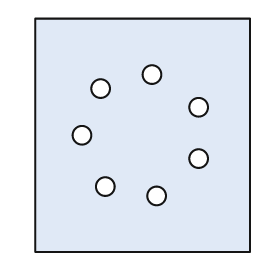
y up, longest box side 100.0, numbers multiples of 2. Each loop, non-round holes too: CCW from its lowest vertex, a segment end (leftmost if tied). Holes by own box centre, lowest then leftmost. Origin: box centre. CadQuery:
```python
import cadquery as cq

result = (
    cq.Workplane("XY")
    .moveTo(-46.0, -50.0)
    .lineTo(46.0, -50.0)
    .lineTo(46.0, 50.0)
    .lineTo(-46.0, 50.0)
    .close()
    .moveTo(6.0, -26.0)
    .circle(4.0)
    .moveTo(-16.0, -22.0)
    .circle(4.0)
    .moveTo(24.0, -10.0)
    .circle(4.0)
    .moveTo(-26.0, 0.0)
    .circle(4.0)
    .moveTo(24.0, 12.0)
    .circle(4.0)
    .moveTo(-18.0, 20.0)
    .circle(4.0)
    .moveTo(4.0, 26.0)
    .circle(4.0)
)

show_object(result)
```